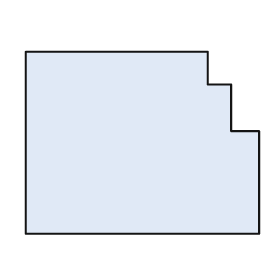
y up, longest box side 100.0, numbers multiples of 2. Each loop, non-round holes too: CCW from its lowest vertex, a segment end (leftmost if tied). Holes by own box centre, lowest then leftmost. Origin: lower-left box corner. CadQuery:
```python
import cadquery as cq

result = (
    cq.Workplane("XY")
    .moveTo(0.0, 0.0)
    .lineTo(100.0, 0.0)
    .lineTo(100.0, 44.0)
    .lineTo(88.0, 44.0)
    .lineTo(88.0, 64.0)
    .lineTo(78.0, 64.0)
    .lineTo(78.0, 78.0)
    .lineTo(0.0, 78.0)
    .close()
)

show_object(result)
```